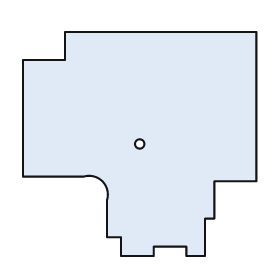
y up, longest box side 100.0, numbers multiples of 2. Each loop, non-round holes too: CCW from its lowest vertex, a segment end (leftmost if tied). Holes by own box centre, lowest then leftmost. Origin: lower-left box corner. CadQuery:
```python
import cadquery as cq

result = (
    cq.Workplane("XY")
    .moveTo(42.0, 0.0)
    .lineTo(56.0, 0.0)
    .lineTo(56.0, 4.0)
    .lineTo(70.0, 4.0)
    .lineTo(70.0, 0.0)
    .lineTo(78.0, 0.0)
    .lineTo(78.0, 16.0)
    .lineTo(82.0, 16.0)
    .lineTo(82.0, 32.0)
    .lineTo(100.0, 32.0)
    .lineTo(100.0, 96.0)
    .lineTo(18.0, 96.0)
    .lineTo(18.0, 84.0)
    .lineTo(0.0, 84.0)
    .lineTo(0.0, 34.0)
    .lineTo(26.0, 34.0)
    .threePointArc((34.0, 32.0), (36.0, 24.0))
    .lineTo(36.0, 8.0)
    .lineTo(42.0, 8.0)
    .close()
    .moveTo(50.0, 48.0)
    .circle(2.0)
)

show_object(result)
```